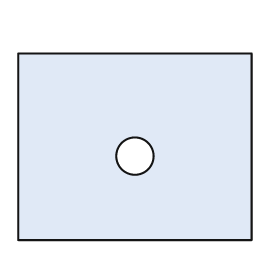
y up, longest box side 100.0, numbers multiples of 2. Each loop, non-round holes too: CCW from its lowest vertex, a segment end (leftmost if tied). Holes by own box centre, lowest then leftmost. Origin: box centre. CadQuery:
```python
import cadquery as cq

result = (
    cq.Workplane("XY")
    .moveTo(-50.0, -40.0)
    .lineTo(50.0, -40.0)
    .lineTo(50.0, 40.0)
    .lineTo(-50.0, 40.0)
    .close()
    .moveTo(0.0, -4.0)
    .circle(8.0)
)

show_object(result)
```